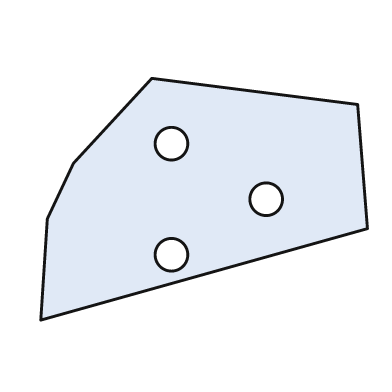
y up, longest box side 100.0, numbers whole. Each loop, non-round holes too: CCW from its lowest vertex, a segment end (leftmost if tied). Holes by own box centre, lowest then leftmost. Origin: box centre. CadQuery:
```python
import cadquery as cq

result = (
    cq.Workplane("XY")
    .moveTo(-50.0, -37.0)
    .lineTo(50.0, -9.0)
    .lineTo(47.0, 29.0)
    .lineTo(-16.0, 37.0)
    .lineTo(-40.0, 11.0)
    .lineTo(-48.0, -6.0)
    .close()
    .moveTo(-10.0, -17.0)
    .circle(5.0)
    .moveTo(19.0, 0.0)
    .circle(5.0)
    .moveTo(-10.0, 17.0)
    .circle(5.0)
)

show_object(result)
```